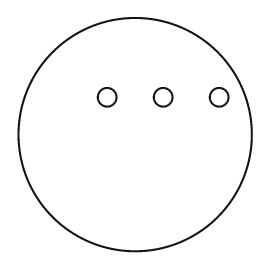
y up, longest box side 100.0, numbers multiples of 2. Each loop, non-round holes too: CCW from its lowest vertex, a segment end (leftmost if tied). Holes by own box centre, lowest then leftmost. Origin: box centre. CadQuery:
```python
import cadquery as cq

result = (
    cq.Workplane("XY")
    .moveTo(0.0, 0.0)
    .circle(50.0)
    .moveTo(-12.0, 16.0)
    .circle(4.0)
    .moveTo(12.0, 16.0)
    .circle(4.0)
    .moveTo(36.0, 16.0)
    .circle(4.0)
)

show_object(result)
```